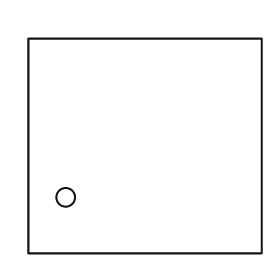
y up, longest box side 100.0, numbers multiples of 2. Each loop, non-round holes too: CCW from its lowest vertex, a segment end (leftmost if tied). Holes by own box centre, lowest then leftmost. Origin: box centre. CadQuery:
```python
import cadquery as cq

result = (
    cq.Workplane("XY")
    .moveTo(-50.0, -46.0)
    .lineTo(50.0, -46.0)
    .lineTo(50.0, 46.0)
    .lineTo(-50.0, 46.0)
    .close()
    .moveTo(-34.0, -22.0)
    .circle(4.0)
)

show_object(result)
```